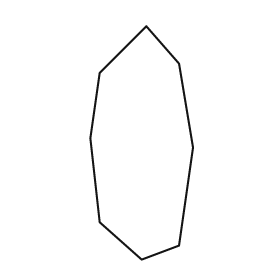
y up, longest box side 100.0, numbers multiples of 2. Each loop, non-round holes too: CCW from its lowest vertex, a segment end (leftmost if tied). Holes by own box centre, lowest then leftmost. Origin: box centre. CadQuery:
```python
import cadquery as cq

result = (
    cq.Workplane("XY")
    .moveTo(0.0, -50.0)
    .lineTo(16.0, -44.0)
    .lineTo(22.0, -2.0)
    .lineTo(16.0, 34.0)
    .lineTo(2.0, 50.0)
    .lineTo(-18.0, 30.0)
    .lineTo(-22.0, 2.0)
    .lineTo(-18.0, -34.0)
    .close()
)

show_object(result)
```